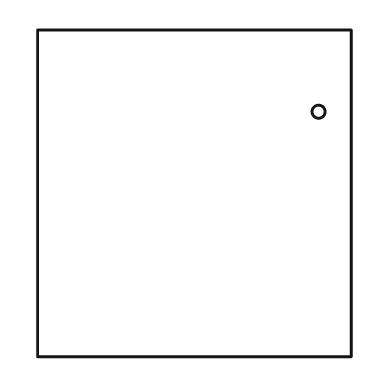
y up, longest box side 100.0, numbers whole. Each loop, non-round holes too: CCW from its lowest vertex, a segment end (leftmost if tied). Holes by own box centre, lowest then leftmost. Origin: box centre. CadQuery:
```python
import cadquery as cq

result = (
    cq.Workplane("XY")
    .moveTo(-48.0, -50.0)
    .lineTo(48.0, -50.0)
    .lineTo(48.0, 50.0)
    .lineTo(-48.0, 50.0)
    .close()
    .moveTo(38.0, 25.0)
    .circle(2.0)
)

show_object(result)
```